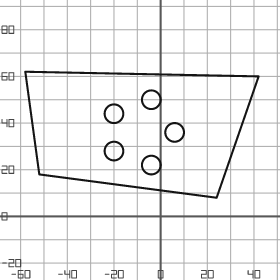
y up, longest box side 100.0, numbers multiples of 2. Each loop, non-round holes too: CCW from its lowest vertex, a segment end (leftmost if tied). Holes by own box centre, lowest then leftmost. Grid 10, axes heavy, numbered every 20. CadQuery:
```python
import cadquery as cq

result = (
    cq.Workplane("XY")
    .moveTo(24.0, 8.0)
    .lineTo(42.0, 60.0)
    .lineTo(-58.0, 62.0)
    .lineTo(-52.0, 18.0)
    .close()
    .moveTo(-4.0, 22.0)
    .circle(4.0)
    .moveTo(-20.0, 28.0)
    .circle(4.0)
    .moveTo(6.0, 36.0)
    .circle(4.0)
    .moveTo(-20.0, 44.0)
    .circle(4.0)
    .moveTo(-4.0, 50.0)
    .circle(4.0)
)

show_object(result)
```